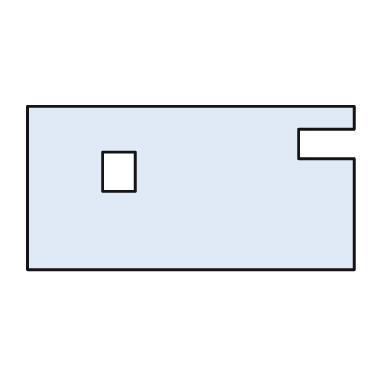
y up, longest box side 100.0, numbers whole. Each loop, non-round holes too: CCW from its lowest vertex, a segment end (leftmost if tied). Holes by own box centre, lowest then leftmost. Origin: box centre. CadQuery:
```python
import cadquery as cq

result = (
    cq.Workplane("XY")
    .moveTo(-50.0, -25.0)
    .lineTo(50.0, -25.0)
    .lineTo(50.0, 9.0)
    .lineTo(33.0, 9.0)
    .lineTo(33.0, 18.0)
    .lineTo(50.0, 18.0)
    .lineTo(50.0, 25.0)
    .lineTo(-50.0, 25.0)
    .close()
    .moveTo(-27.0, -1.0)
    .lineTo(-17.0, -1.0)
    .lineTo(-17.0, 11.0)
    .lineTo(-27.0, 11.0)
    .close()
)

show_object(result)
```